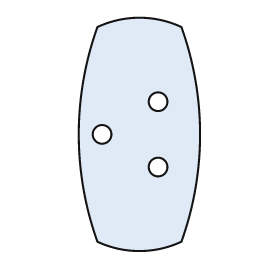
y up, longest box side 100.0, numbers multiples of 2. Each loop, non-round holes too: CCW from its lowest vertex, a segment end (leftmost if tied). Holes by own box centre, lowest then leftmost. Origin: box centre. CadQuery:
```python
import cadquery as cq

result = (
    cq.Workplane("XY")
    .moveTo(-18.0, -46.0)
    .threePointArc((0.0, -50.0), (18.0, -46.0))
    .threePointArc((26.0, 0.0), (18.0, 46.0))
    .threePointArc((0.0, 50.0), (-18.0, 46.0))
    .threePointArc((-26.0, 0.0), (-18.0, -46.0))
    .close()
    .moveTo(8.0, -14.0)
    .circle(4.0)
    .moveTo(-16.0, 0.0)
    .circle(4.0)
    .moveTo(8.0, 14.0)
    .circle(4.0)
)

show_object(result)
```